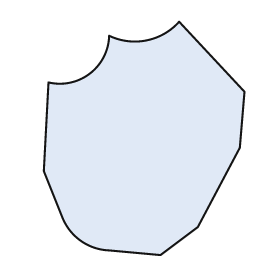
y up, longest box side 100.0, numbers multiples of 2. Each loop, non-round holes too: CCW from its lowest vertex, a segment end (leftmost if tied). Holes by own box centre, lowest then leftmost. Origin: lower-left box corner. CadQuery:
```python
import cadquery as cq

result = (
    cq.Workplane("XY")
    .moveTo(50.0, 0.0)
    .lineTo(66.0, 12.0)
    .lineTo(84.0, 46.0)
    .lineTo(86.0, 70.0)
    .lineTo(58.0, 100.0)
    .threePointArc((44.0, 92.0), (28.0, 94.0))
    .threePointArc((20.0, 78.0), (2.0, 74.0))
    .lineTo(0.0, 36.0)
    .lineTo(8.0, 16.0)
    .threePointArc((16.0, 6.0), (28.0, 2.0))
    .close()
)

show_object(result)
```